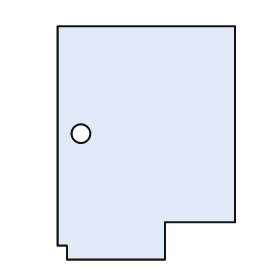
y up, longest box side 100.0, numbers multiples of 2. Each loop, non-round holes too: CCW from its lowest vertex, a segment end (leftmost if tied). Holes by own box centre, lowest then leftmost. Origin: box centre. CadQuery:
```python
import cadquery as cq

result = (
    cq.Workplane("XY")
    .moveTo(-34.0, -50.0)
    .lineTo(8.0, -50.0)
    .lineTo(8.0, -34.0)
    .lineTo(38.0, -34.0)
    .lineTo(38.0, 50.0)
    .lineTo(-38.0, 50.0)
    .lineTo(-38.0, -44.0)
    .lineTo(-34.0, -44.0)
    .close()
    .moveTo(-28.0, 4.0)
    .circle(4.0)
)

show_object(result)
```